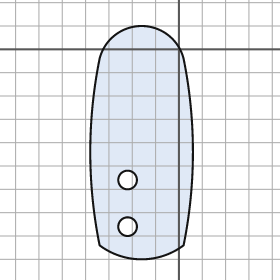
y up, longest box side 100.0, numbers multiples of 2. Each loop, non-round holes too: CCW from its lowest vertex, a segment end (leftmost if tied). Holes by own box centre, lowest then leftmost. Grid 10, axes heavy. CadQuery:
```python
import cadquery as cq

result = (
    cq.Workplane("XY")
    .moveTo(-34.0, -84.0)
    .threePointArc((-16.0, -90.0), (2.0, -84.0))
    .threePointArc((6.0, -44.0), (2.0, -4.0))
    .threePointArc((-16.0, 10.0), (-34.0, -4.0))
    .threePointArc((-38.0, -44.0), (-34.0, -84.0))
    .close()
    .moveTo(-22.0, -76.0)
    .circle(4.0)
    .moveTo(-22.0, -56.0)
    .circle(4.0)
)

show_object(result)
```